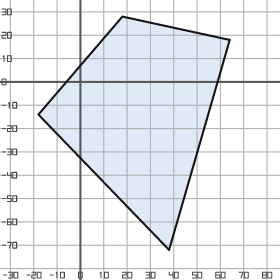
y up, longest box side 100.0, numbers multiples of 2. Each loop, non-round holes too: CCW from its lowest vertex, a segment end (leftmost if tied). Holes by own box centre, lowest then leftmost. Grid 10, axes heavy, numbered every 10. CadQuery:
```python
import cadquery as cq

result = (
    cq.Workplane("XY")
    .moveTo(38.0, -72.0)
    .lineTo(64.0, 18.0)
    .lineTo(18.0, 28.0)
    .lineTo(-18.0, -14.0)
    .close()
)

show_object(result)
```